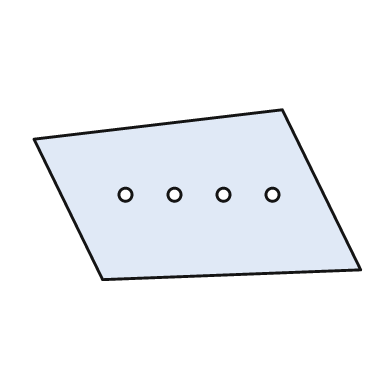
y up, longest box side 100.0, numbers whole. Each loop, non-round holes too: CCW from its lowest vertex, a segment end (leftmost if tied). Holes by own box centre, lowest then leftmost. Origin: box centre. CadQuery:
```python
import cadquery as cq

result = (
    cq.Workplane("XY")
    .moveTo(-29.0, -26.0)
    .lineTo(50.0, -23.0)
    .lineTo(26.0, 26.0)
    .lineTo(-50.0, 17.0)
    .close()
    .moveTo(-22.0, 0.0)
    .circle(2.0)
    .moveTo(-7.0, 0.0)
    .circle(2.0)
    .moveTo(8.0, 0.0)
    .circle(2.0)
    .moveTo(23.0, 0.0)
    .circle(2.0)
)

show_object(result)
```